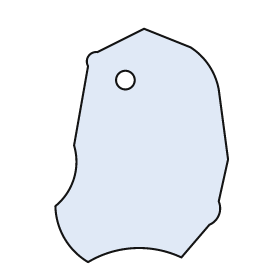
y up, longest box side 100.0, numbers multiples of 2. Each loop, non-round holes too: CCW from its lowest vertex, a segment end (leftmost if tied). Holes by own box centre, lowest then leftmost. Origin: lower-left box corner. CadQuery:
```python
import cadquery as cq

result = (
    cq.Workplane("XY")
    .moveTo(14.0, 0.0)
    .threePointArc((34.0, 6.0), (54.0, 2.0))
    .lineTo(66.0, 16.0)
    .threePointArc((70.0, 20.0), (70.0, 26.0))
    .lineTo(74.0, 44.0)
    .lineTo(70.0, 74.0)
    .threePointArc((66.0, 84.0), (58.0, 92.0))
    .lineTo(38.0, 100.0)
    .lineTo(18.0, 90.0)
    .threePointArc((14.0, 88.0), (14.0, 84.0))
    .lineTo(8.0, 50.0)
    .threePointArc((8.0, 36.0), (0.0, 24.0))
    .threePointArc((4.0, 10.0), (14.0, 0.0))
    .close()
    .moveTo(30.0, 78.0)
    .circle(4.0)
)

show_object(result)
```